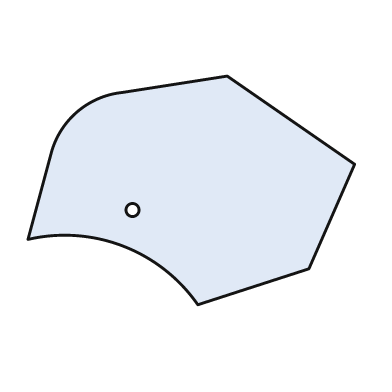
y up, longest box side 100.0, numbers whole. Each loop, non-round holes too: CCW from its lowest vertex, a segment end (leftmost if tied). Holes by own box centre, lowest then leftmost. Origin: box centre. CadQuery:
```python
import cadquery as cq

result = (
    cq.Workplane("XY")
    .moveTo(2.0, -35.0)
    .lineTo(36.0, -24.0)
    .lineTo(50.0, 8.0)
    .lineTo(11.0, 35.0)
    .lineTo(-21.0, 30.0)
    .threePointArc((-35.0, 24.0), (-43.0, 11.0))
    .lineTo(-50.0, -15.0)
    .threePointArc((-21.0, -17.0), (2.0, -35.0))
    .close()
    .moveTo(-18.0, -6.0)
    .circle(2.0)
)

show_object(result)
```